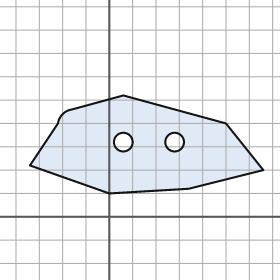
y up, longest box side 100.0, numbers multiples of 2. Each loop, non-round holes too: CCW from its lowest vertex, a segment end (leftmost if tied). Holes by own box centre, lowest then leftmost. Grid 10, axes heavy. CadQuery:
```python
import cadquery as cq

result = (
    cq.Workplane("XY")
    .moveTo(0.0, 10.0)
    .lineTo(34.0, 12.0)
    .lineTo(66.0, 20.0)
    .lineTo(50.0, 40.0)
    .lineTo(6.0, 52.0)
    .lineTo(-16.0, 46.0)
    .threePointArc((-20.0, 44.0), (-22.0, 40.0))
    .lineTo(-34.0, 22.0)
    .close()
    .moveTo(6.0, 32.0)
    .circle(4.0)
    .moveTo(28.0, 32.0)
    .circle(4.0)
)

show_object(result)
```